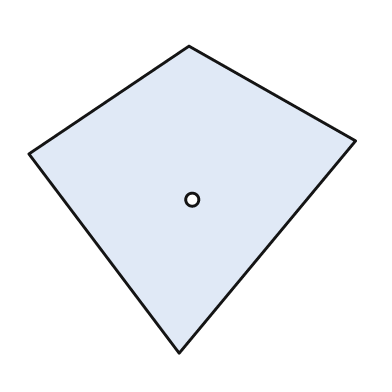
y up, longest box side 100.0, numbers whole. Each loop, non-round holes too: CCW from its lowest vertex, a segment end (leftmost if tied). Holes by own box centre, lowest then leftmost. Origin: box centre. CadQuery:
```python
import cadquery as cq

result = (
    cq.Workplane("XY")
    .moveTo(-4.0, -47.0)
    .lineTo(50.0, 18.0)
    .lineTo(-1.0, 47.0)
    .lineTo(-50.0, 14.0)
    .close()
    .moveTo(0.0, 0.0)
    .circle(2.0)
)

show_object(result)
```